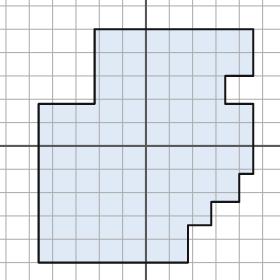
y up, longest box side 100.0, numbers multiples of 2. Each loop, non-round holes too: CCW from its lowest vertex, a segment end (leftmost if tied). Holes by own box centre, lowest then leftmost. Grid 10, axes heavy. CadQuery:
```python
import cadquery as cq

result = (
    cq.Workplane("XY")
    .moveTo(-46.0, -50.0)
    .lineTo(18.0, -50.0)
    .lineTo(18.0, -34.0)
    .lineTo(28.0, -34.0)
    .lineTo(28.0, -24.0)
    .lineTo(40.0, -24.0)
    .lineTo(40.0, -12.0)
    .lineTo(46.0, -12.0)
    .lineTo(46.0, 18.0)
    .lineTo(34.0, 18.0)
    .lineTo(34.0, 30.0)
    .lineTo(46.0, 30.0)
    .lineTo(46.0, 50.0)
    .lineTo(-22.0, 50.0)
    .lineTo(-22.0, 18.0)
    .lineTo(-46.0, 18.0)
    .close()
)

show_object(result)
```